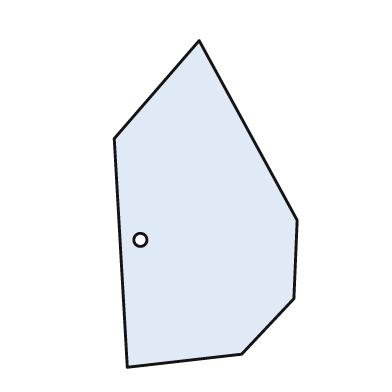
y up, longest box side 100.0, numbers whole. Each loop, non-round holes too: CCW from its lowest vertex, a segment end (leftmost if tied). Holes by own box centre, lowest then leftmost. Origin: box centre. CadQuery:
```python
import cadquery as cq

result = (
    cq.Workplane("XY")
    .moveTo(-24.0, -50.0)
    .lineTo(11.0, -46.0)
    .lineTo(27.0, -29.0)
    .lineTo(28.0, -5.0)
    .lineTo(-2.0, 50.0)
    .lineTo(-28.0, 20.0)
    .close()
    .moveTo(-20.0, -11.0)
    .circle(2.0)
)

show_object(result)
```